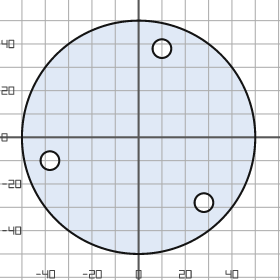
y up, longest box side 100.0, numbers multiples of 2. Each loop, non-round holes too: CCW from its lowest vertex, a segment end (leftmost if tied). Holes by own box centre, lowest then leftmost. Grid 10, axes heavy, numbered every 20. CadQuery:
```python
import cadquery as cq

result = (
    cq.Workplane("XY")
    .moveTo(0.0, 0.0)
    .circle(50.0)
    .moveTo(28.0, -28.0)
    .circle(4.0)
    .moveTo(-38.0, -10.0)
    .circle(4.0)
    .moveTo(10.0, 38.0)
    .circle(4.0)
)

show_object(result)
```